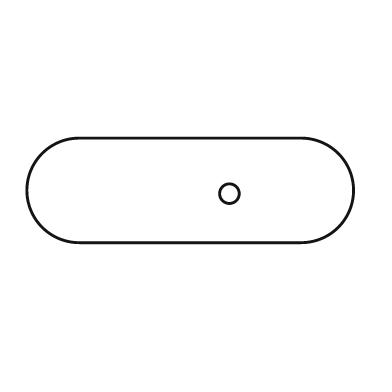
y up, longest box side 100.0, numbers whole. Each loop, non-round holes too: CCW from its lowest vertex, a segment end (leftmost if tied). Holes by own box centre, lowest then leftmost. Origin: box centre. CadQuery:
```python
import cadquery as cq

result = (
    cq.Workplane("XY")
    .moveTo(-34.0, -16.0)
    .lineTo(34.0, -16.0)
    .threePointArc((50.0, 0.0), (34.0, 16.0))
    .lineTo(-34.0, 16.0)
    .threePointArc((-50.0, 0.0), (-34.0, -16.0))
    .close()
    .moveTo(12.0, -1.0)
    .circle(3.0)
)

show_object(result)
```